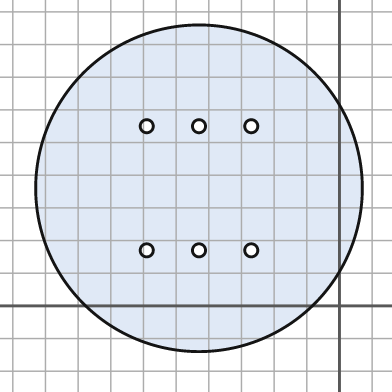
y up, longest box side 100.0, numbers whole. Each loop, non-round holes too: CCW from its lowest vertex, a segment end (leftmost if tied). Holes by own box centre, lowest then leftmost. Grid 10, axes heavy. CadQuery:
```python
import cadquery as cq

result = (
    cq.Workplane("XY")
    .moveTo(-43.0, 36.0)
    .circle(50.0)
    .moveTo(-59.0, 17.0)
    .circle(2.0)
    .moveTo(-43.0, 17.0)
    .circle(2.0)
    .moveTo(-27.0, 17.0)
    .circle(2.0)
    .moveTo(-59.0, 55.0)
    .circle(2.0)
    .moveTo(-43.0, 55.0)
    .circle(2.0)
    .moveTo(-27.0, 55.0)
    .circle(2.0)
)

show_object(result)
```